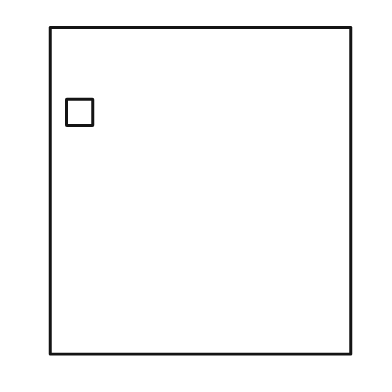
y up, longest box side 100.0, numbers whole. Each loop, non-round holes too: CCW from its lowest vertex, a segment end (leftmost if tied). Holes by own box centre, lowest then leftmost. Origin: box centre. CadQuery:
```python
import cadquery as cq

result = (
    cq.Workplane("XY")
    .moveTo(-46.0, -50.0)
    .lineTo(46.0, -50.0)
    .lineTo(46.0, 50.0)
    .lineTo(-46.0, 50.0)
    .close()
    .moveTo(-41.0, 20.0)
    .lineTo(-33.0, 20.0)
    .lineTo(-33.0, 28.0)
    .lineTo(-41.0, 28.0)
    .close()
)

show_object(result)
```